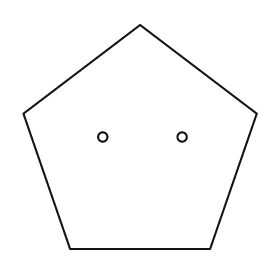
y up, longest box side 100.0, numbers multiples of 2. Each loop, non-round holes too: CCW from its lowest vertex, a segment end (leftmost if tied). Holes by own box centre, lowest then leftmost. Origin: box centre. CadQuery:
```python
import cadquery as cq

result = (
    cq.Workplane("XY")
    .moveTo(-30.0, -48.0)
    .lineTo(30.0, -48.0)
    .lineTo(50.0, 10.0)
    .lineTo(0.0, 48.0)
    .lineTo(-50.0, 10.0)
    .close()
    .moveTo(-16.0, 0.0)
    .circle(2.0)
    .moveTo(18.0, 0.0)
    .circle(2.0)
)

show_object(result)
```